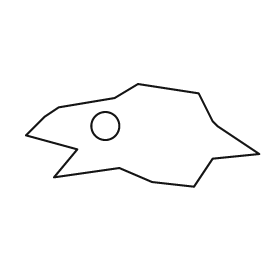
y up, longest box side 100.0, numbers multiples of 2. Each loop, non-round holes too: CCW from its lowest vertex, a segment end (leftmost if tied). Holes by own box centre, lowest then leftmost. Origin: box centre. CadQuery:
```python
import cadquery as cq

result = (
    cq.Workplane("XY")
    .moveTo(22.0, -22.0)
    .lineTo(30.0, -10.0)
    .lineTo(50.0, -8.0)
    .lineTo(32.0, 4.0)
    .lineTo(30.0, 6.0)
    .lineTo(24.0, 18.0)
    .lineTo(-2.0, 22.0)
    .lineTo(-12.0, 16.0)
    .lineTo(-36.0, 12.0)
    .lineTo(-42.0, 8.0)
    .lineTo(-50.0, 0.0)
    .lineTo(-28.0, -6.0)
    .lineTo(-38.0, -18.0)
    .lineTo(-10.0, -14.0)
    .lineTo(4.0, -20.0)
    .close()
    .moveTo(-16.0, 4.0)
    .circle(6.0)
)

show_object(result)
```